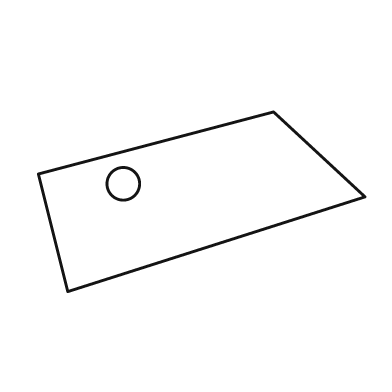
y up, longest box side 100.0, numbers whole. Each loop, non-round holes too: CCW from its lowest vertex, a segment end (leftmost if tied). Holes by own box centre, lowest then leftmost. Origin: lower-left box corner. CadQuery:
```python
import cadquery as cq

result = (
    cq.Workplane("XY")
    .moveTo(9.0, 0.0)
    .lineTo(100.0, 29.0)
    .lineTo(72.0, 55.0)
    .lineTo(0.0, 36.0)
    .close()
    .moveTo(26.0, 33.0)
    .circle(5.0)
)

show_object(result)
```